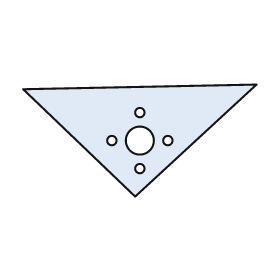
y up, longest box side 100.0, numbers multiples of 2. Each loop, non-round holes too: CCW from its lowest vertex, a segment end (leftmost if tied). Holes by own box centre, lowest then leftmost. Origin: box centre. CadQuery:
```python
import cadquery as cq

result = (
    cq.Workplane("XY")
    .moveTo(-2.0, -24.0)
    .lineTo(50.0, 24.0)
    .lineTo(-50.0, 22.0)
    .close()
    .moveTo(0.0, -12.0)
    .circle(2.0)
    .moveTo(-12.0, 0.0)
    .circle(2.0)
    .moveTo(0.0, 0.0)
    .circle(6.0)
    .moveTo(12.0, 0.0)
    .circle(2.0)
    .moveTo(0.0, 12.0)
    .circle(2.0)
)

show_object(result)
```